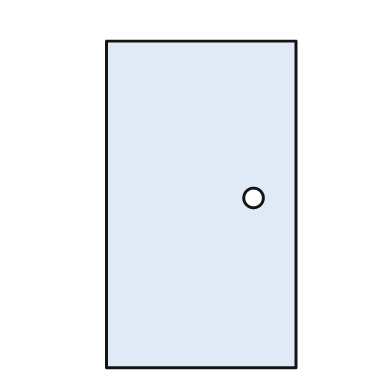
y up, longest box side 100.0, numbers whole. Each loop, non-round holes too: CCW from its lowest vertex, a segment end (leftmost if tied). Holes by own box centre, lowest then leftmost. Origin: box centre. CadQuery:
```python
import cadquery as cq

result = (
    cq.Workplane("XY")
    .moveTo(-29.0, -50.0)
    .lineTo(29.0, -50.0)
    .lineTo(29.0, 50.0)
    .lineTo(-29.0, 50.0)
    .close()
    .moveTo(16.0, 2.0)
    .circle(3.0)
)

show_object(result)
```